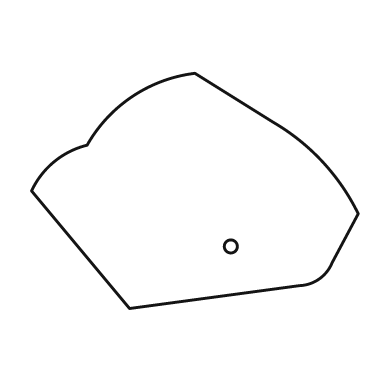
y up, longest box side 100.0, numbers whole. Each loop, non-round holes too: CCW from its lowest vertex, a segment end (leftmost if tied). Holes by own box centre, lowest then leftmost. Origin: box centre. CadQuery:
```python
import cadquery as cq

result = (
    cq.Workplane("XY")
    .moveTo(-20.0, -36.0)
    .lineTo(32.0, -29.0)
    .threePointArc((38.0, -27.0), (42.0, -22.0))
    .lineTo(50.0, -7.0)
    .threePointArc((39.0, 9.0), (24.0, 21.0))
    .lineTo(0.0, 36.0)
    .threePointArc((-19.0, 29.0), (-33.0, 14.0))
    .threePointArc((-43.0, 9.0), (-50.0, 0.0))
    .close()
    .moveTo(11.0, -17.0)
    .circle(2.0)
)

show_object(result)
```